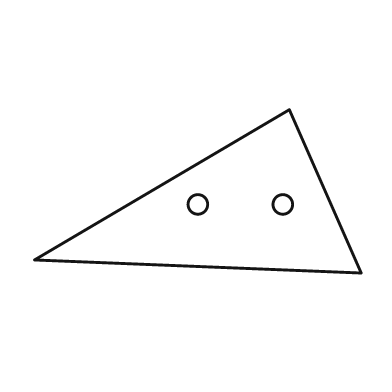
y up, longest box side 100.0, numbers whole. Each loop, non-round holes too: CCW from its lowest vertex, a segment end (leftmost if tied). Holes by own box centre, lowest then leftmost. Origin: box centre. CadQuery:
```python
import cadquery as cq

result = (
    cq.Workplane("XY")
    .moveTo(50.0, -25.0)
    .lineTo(28.0, 25.0)
    .lineTo(-50.0, -21.0)
    .close()
    .moveTo(0.0, -4.0)
    .circle(3.0)
    .moveTo(26.0, -4.0)
    .circle(3.0)
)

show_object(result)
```